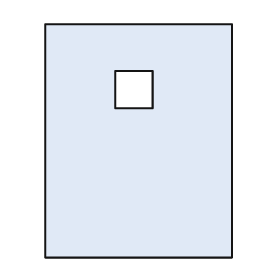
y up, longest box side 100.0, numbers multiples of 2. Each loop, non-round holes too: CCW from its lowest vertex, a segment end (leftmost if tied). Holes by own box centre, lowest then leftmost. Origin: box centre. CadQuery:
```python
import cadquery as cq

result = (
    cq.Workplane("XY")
    .moveTo(-40.0, -50.0)
    .lineTo(40.0, -50.0)
    .lineTo(40.0, 50.0)
    .lineTo(-40.0, 50.0)
    .close()
    .moveTo(-10.0, 14.0)
    .lineTo(6.0, 14.0)
    .lineTo(6.0, 30.0)
    .lineTo(-10.0, 30.0)
    .close()
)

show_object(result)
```